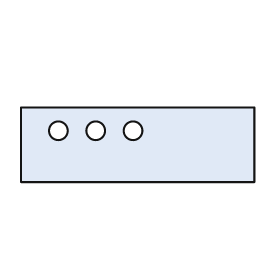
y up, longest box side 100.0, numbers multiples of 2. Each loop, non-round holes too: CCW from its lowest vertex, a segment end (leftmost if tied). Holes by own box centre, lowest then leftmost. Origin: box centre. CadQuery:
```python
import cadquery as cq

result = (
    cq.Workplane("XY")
    .moveTo(-50.0, -16.0)
    .lineTo(50.0, -16.0)
    .lineTo(50.0, 16.0)
    .lineTo(-50.0, 16.0)
    .close()
    .moveTo(-34.0, 6.0)
    .circle(4.0)
    .moveTo(-18.0, 6.0)
    .circle(4.0)
    .moveTo(-2.0, 6.0)
    .circle(4.0)
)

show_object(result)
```